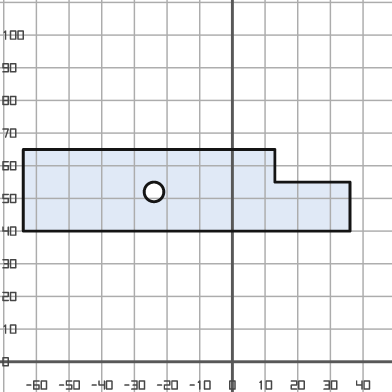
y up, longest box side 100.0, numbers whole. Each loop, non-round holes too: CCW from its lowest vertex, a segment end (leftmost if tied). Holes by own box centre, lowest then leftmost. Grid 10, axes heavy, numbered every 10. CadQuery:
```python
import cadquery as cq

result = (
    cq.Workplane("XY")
    .moveTo(-64.0, 40.0)
    .lineTo(36.0, 40.0)
    .lineTo(36.0, 55.0)
    .lineTo(13.0, 55.0)
    .lineTo(13.0, 65.0)
    .lineTo(-64.0, 65.0)
    .close()
    .moveTo(-24.0, 52.0)
    .circle(3.0)
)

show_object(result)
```